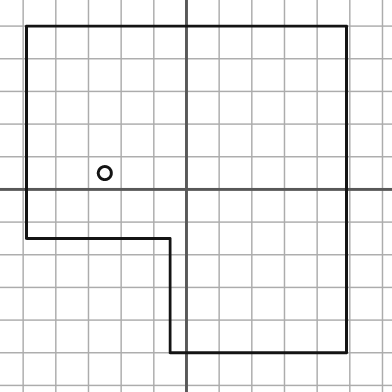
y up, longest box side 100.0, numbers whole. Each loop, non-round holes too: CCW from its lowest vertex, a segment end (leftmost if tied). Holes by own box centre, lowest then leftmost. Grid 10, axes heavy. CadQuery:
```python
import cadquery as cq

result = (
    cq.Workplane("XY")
    .moveTo(-5.0, -50.0)
    .lineTo(49.0, -50.0)
    .lineTo(49.0, 50.0)
    .lineTo(-49.0, 50.0)
    .lineTo(-49.0, -15.0)
    .lineTo(-5.0, -15.0)
    .close()
    .moveTo(-25.0, 5.0)
    .circle(2.0)
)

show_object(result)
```